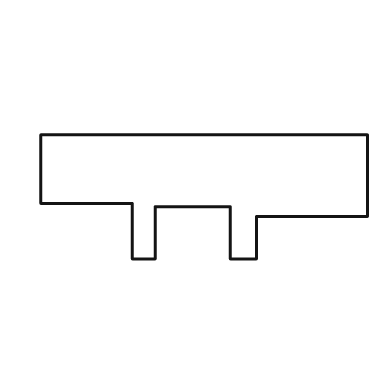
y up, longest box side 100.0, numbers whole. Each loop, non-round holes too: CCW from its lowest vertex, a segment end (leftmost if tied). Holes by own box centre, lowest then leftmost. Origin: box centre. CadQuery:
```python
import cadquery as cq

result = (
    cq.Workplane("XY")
    .moveTo(-22.0, -19.0)
    .lineTo(-15.0, -19.0)
    .lineTo(-15.0, -3.0)
    .lineTo(8.0, -3.0)
    .lineTo(8.0, -19.0)
    .lineTo(16.0, -19.0)
    .lineTo(16.0, -6.0)
    .lineTo(50.0, -6.0)
    .lineTo(50.0, 19.0)
    .lineTo(-50.0, 19.0)
    .lineTo(-50.0, -2.0)
    .lineTo(-22.0, -2.0)
    .close()
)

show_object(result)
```